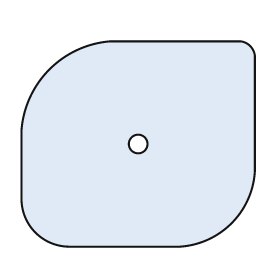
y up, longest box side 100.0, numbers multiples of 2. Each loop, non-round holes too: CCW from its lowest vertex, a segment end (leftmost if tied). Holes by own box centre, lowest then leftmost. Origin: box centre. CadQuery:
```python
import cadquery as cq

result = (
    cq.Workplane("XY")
    .moveTo(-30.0, -44.0)
    .lineTo(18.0, -44.0)
    .threePointArc((40.0, -34.0), (50.0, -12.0))
    .lineTo(50.0, 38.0)
    .threePointArc((48.0, 42.0), (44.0, 44.0))
    .lineTo(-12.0, 44.0)
    .threePointArc((-38.0, 32.0), (-50.0, 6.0))
    .lineTo(-50.0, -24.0)
    .threePointArc((-44.0, -38.0), (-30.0, -44.0))
    .close()
    .moveTo(0.0, 0.0)
    .circle(4.0)
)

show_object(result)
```